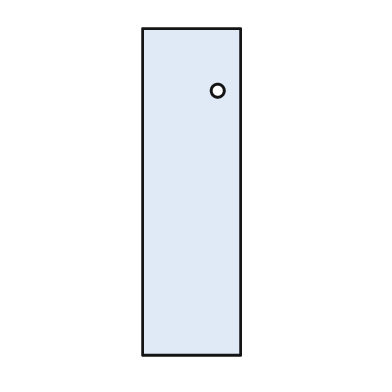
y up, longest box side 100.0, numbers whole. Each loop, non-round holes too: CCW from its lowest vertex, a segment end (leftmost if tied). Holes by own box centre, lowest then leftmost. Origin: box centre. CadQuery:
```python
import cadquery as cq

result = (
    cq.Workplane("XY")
    .moveTo(-15.0, -50.0)
    .lineTo(15.0, -50.0)
    .lineTo(15.0, 50.0)
    .lineTo(-15.0, 50.0)
    .close()
    .moveTo(8.0, 31.0)
    .circle(2.0)
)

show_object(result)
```